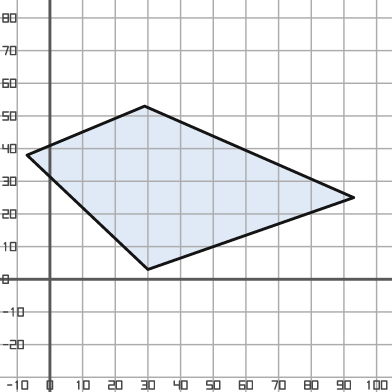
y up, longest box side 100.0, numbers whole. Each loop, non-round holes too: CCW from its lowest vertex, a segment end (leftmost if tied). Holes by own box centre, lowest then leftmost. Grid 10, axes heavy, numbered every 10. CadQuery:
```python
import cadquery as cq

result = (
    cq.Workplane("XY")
    .moveTo(30.0, 3.0)
    .lineTo(93.0, 25.0)
    .lineTo(29.0, 53.0)
    .lineTo(-7.0, 38.0)
    .close()
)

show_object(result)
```